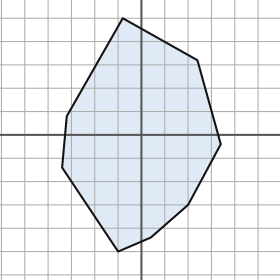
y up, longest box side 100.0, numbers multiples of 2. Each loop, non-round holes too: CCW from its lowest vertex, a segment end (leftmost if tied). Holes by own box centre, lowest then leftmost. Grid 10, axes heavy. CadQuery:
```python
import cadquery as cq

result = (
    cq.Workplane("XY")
    .moveTo(-10.0, -50.0)
    .lineTo(4.0, -44.0)
    .lineTo(20.0, -30.0)
    .lineTo(34.0, -4.0)
    .lineTo(24.0, 32.0)
    .lineTo(-8.0, 50.0)
    .lineTo(-32.0, 8.0)
    .lineTo(-34.0, -14.0)
    .close()
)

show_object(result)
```